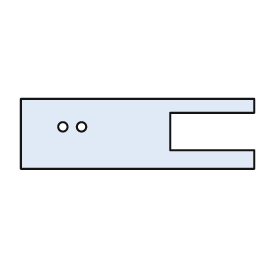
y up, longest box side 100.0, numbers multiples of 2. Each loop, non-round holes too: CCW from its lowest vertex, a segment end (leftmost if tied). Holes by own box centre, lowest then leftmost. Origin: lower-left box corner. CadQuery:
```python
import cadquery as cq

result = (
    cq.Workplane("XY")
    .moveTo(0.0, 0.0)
    .lineTo(100.0, 0.0)
    .lineTo(100.0, 8.0)
    .lineTo(64.0, 8.0)
    .lineTo(64.0, 24.0)
    .lineTo(100.0, 24.0)
    .lineTo(100.0, 30.0)
    .lineTo(0.0, 30.0)
    .close()
    .moveTo(18.0, 18.0)
    .circle(2.0)
    .moveTo(26.0, 18.0)
    .circle(2.0)
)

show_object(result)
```